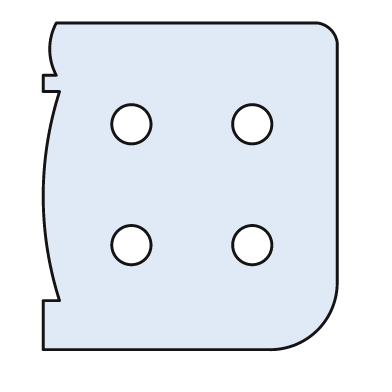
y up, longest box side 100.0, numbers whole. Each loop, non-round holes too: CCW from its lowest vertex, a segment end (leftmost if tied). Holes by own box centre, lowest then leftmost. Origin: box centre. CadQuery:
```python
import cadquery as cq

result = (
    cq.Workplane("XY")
    .moveTo(-45.0, -50.0)
    .lineTo(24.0, -50.0)
    .threePointArc((39.0, -44.0), (45.0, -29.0))
    .lineTo(45.0, 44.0)
    .threePointArc((43.0, 48.0), (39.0, 50.0))
    .lineTo(-41.0, 50.0)
    .threePointArc((-43.0, 42.0), (-41.0, 34.0))
    .lineTo(-45.0, 34.0)
    .lineTo(-45.0, 29.0)
    .lineTo(-40.0, 29.0)
    .threePointArc((-45.0, -3.0), (-40.0, -35.0))
    .lineTo(-45.0, -35.0)
    .close()
    .moveTo(-18.0, -18.0)
    .circle(6.0)
    .moveTo(19.0, -18.0)
    .circle(6.0)
    .moveTo(-18.0, 19.0)
    .circle(6.0)
    .moveTo(19.0, 19.0)
    .circle(6.0)
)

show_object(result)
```